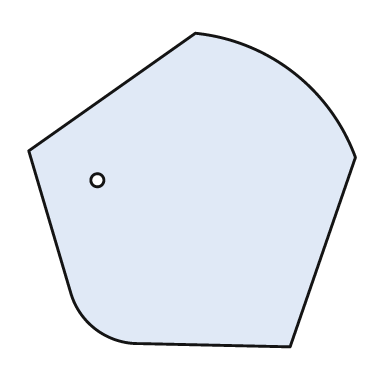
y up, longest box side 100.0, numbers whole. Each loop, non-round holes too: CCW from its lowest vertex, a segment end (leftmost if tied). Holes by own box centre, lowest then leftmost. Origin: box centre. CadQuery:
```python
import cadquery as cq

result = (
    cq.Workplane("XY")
    .moveTo(30.0, -48.0)
    .lineTo(50.0, 10.0)
    .threePointArc((31.0, 36.0), (1.0, 48.0))
    .lineTo(-50.0, 12.0)
    .lineTo(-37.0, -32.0)
    .threePointArc((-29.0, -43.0), (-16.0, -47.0))
    .close()
    .moveTo(-29.0, 3.0)
    .circle(2.0)
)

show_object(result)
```